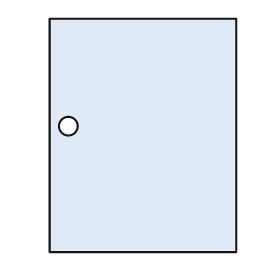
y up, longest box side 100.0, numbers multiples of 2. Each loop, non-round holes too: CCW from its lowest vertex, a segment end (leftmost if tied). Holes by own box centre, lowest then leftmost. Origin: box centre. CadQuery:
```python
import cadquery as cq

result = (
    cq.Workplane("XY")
    .moveTo(-40.0, -50.0)
    .lineTo(40.0, -50.0)
    .lineTo(40.0, 50.0)
    .lineTo(-40.0, 50.0)
    .close()
    .moveTo(-32.0, 4.0)
    .circle(4.0)
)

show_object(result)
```